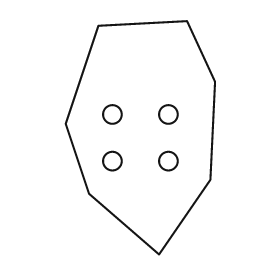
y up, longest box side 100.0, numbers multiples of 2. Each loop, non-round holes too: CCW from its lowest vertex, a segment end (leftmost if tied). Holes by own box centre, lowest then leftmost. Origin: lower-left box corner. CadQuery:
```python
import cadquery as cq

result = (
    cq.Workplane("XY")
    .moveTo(40.0, 0.0)
    .lineTo(62.0, 32.0)
    .lineTo(64.0, 74.0)
    .lineTo(52.0, 100.0)
    .lineTo(14.0, 98.0)
    .lineTo(0.0, 56.0)
    .lineTo(10.0, 26.0)
    .close()
    .moveTo(20.0, 40.0)
    .circle(4.0)
    .moveTo(44.0, 40.0)
    .circle(4.0)
    .moveTo(20.0, 60.0)
    .circle(4.0)
    .moveTo(44.0, 60.0)
    .circle(4.0)
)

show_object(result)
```